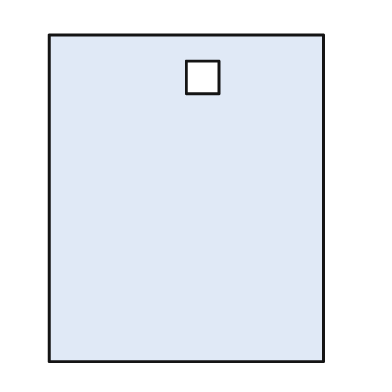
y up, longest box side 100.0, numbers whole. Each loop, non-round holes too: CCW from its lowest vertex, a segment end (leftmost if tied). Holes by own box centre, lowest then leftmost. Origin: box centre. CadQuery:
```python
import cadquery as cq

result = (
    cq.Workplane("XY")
    .moveTo(-42.0, -50.0)
    .lineTo(42.0, -50.0)
    .lineTo(42.0, 50.0)
    .lineTo(-42.0, 50.0)
    .close()
    .moveTo(0.0, 32.0)
    .lineTo(10.0, 32.0)
    .lineTo(10.0, 42.0)
    .lineTo(0.0, 42.0)
    .close()
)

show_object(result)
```